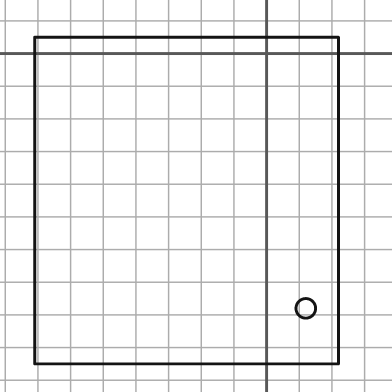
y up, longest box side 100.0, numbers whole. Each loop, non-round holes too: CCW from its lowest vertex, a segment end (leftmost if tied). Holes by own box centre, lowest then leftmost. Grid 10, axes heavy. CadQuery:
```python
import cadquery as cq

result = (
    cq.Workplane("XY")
    .moveTo(-71.0, -95.0)
    .lineTo(22.0, -95.0)
    .lineTo(22.0, 5.0)
    .lineTo(-71.0, 5.0)
    .close()
    .moveTo(12.0, -78.0)
    .circle(3.0)
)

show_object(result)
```